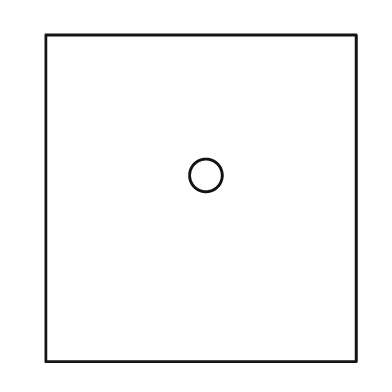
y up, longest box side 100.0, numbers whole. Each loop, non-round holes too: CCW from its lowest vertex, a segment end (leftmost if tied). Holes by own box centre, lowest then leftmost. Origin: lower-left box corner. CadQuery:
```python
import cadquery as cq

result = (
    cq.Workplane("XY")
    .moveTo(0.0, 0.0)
    .lineTo(95.0, 0.0)
    .lineTo(95.0, 100.0)
    .lineTo(0.0, 100.0)
    .close()
    .moveTo(49.0, 57.0)
    .circle(5.0)
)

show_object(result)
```